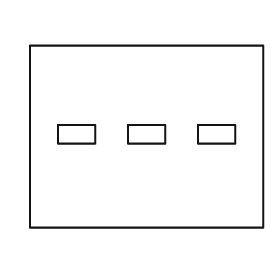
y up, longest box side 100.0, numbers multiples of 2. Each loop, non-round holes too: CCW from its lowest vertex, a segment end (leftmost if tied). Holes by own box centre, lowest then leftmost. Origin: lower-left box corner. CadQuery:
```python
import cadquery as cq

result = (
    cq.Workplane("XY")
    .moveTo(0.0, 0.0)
    .lineTo(100.0, 0.0)
    .lineTo(100.0, 78.0)
    .lineTo(0.0, 78.0)
    .close()
    .moveTo(12.0, 36.0)
    .lineTo(28.0, 36.0)
    .lineTo(28.0, 44.0)
    .lineTo(12.0, 44.0)
    .close()
    .moveTo(42.0, 36.0)
    .lineTo(58.0, 36.0)
    .lineTo(58.0, 44.0)
    .lineTo(42.0, 44.0)
    .close()
    .moveTo(72.0, 36.0)
    .lineTo(88.0, 36.0)
    .lineTo(88.0, 44.0)
    .lineTo(72.0, 44.0)
    .close()
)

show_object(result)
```